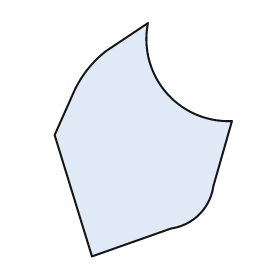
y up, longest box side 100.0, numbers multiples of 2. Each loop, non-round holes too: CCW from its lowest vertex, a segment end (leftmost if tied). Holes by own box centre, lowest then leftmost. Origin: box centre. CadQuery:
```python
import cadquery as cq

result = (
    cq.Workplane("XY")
    .moveTo(-22.0, -50.0)
    .lineTo(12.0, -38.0)
    .threePointArc((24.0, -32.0), (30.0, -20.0))
    .lineTo(38.0, 8.0)
    .threePointArc((10.0, 20.0), (2.0, 50.0))
    .lineTo(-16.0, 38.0)
    .threePointArc((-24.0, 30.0), (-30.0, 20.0))
    .lineTo(-38.0, 2.0)
    .close()
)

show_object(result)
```